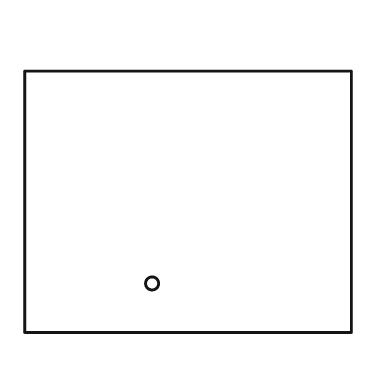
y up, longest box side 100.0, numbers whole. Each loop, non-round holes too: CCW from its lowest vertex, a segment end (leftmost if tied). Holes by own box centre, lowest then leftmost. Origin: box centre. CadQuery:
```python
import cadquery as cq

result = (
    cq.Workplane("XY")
    .moveTo(-50.0, -40.0)
    .lineTo(50.0, -40.0)
    .lineTo(50.0, 40.0)
    .lineTo(-50.0, 40.0)
    .close()
    .moveTo(-11.0, -25.0)
    .circle(2.0)
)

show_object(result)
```